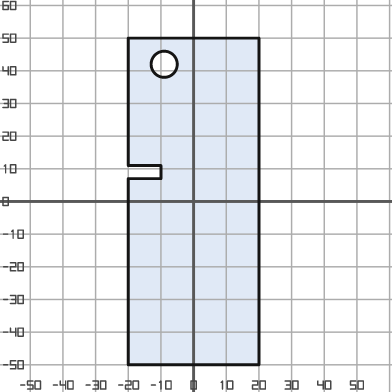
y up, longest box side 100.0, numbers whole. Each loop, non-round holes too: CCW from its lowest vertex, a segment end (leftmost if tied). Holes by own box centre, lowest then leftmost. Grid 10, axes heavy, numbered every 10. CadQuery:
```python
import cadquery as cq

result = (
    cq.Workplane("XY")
    .moveTo(-20.0, -50.0)
    .lineTo(20.0, -50.0)
    .lineTo(20.0, 50.0)
    .lineTo(-20.0, 50.0)
    .lineTo(-20.0, 11.0)
    .lineTo(-10.0, 11.0)
    .lineTo(-10.0, 7.0)
    .lineTo(-20.0, 7.0)
    .close()
    .moveTo(-9.0, 42.0)
    .circle(4.0)
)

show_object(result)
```